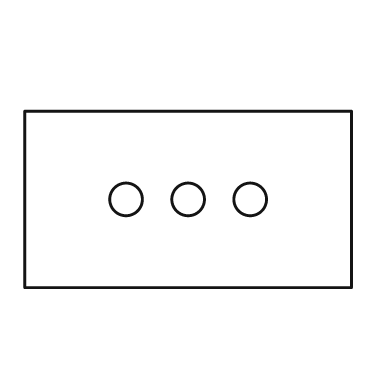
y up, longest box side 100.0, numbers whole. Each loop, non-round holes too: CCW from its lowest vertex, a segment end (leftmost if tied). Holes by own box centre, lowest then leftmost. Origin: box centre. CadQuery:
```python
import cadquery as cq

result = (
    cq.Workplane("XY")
    .moveTo(-50.0, -27.0)
    .lineTo(50.0, -27.0)
    .lineTo(50.0, 27.0)
    .lineTo(-50.0, 27.0)
    .close()
    .moveTo(-19.0, 0.0)
    .circle(5.0)
    .moveTo(0.0, 0.0)
    .circle(5.0)
    .moveTo(19.0, 0.0)
    .circle(5.0)
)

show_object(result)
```